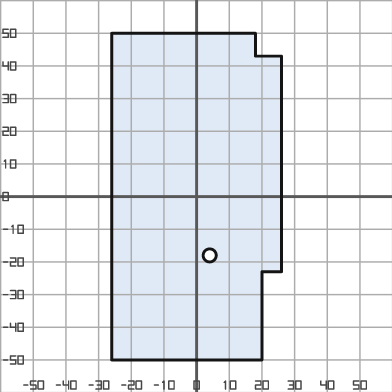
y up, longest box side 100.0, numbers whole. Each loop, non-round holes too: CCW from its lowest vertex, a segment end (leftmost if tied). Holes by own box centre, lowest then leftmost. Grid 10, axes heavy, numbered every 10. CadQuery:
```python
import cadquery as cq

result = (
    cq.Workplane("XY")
    .moveTo(-26.0, -50.0)
    .lineTo(20.0, -50.0)
    .lineTo(20.0, -23.0)
    .lineTo(26.0, -23.0)
    .lineTo(26.0, 43.0)
    .lineTo(18.0, 43.0)
    .lineTo(18.0, 50.0)
    .lineTo(-26.0, 50.0)
    .close()
    .moveTo(4.0, -18.0)
    .circle(2.0)
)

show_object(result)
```